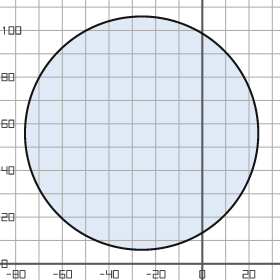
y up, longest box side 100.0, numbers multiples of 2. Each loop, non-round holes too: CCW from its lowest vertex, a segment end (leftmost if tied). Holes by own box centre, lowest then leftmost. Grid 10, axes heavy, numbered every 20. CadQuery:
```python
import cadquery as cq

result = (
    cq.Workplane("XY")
    .moveTo(-26.0, 56.0)
    .circle(50.0)
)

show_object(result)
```